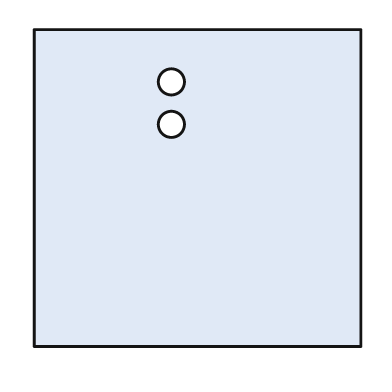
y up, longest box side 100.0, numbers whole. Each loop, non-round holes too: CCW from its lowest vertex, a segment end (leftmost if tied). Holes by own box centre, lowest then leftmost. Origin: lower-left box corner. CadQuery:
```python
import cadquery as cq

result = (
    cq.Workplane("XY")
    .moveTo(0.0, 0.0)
    .lineTo(100.0, 0.0)
    .lineTo(100.0, 97.0)
    .lineTo(0.0, 97.0)
    .close()
    .moveTo(42.0, 68.0)
    .circle(4.0)
    .moveTo(42.0, 81.0)
    .circle(4.0)
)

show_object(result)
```